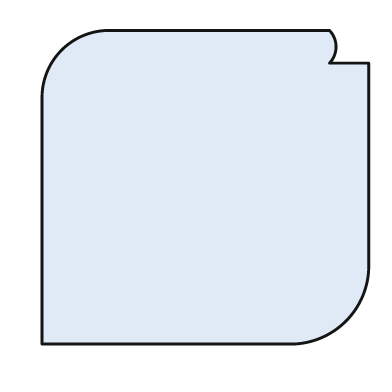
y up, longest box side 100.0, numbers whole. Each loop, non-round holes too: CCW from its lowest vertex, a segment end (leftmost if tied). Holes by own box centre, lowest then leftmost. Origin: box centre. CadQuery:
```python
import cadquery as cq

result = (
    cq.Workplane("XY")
    .moveTo(-50.0, -48.0)
    .lineTo(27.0, -48.0)
    .threePointArc((43.0, -41.0), (50.0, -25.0))
    .lineTo(50.0, 38.0)
    .lineTo(38.0, 38.0)
    .threePointArc((40.0, 43.0), (38.0, 48.0))
    .lineTo(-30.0, 48.0)
    .threePointArc((-44.0, 42.0), (-50.0, 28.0))
    .close()
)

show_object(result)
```